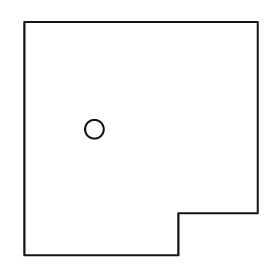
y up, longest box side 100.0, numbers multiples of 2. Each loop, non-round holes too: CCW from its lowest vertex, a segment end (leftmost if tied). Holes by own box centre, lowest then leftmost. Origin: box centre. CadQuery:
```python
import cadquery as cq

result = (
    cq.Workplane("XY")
    .moveTo(-50.0, -50.0)
    .lineTo(16.0, -50.0)
    .lineTo(16.0, -32.0)
    .lineTo(50.0, -32.0)
    .lineTo(50.0, 50.0)
    .lineTo(-50.0, 50.0)
    .close()
    .moveTo(-20.0, 4.0)
    .circle(4.0)
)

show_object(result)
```